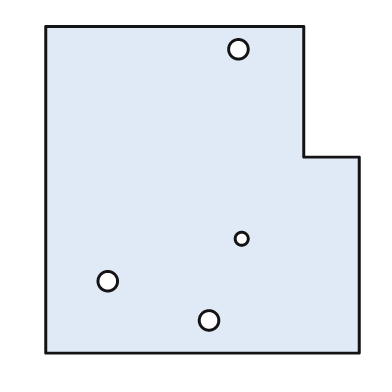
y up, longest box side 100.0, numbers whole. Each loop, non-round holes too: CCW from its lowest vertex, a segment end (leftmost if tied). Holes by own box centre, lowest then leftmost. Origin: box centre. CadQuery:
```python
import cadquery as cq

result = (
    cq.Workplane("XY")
    .moveTo(-48.0, -50.0)
    .lineTo(48.0, -50.0)
    .lineTo(48.0, 10.0)
    .lineTo(31.0, 10.0)
    .lineTo(31.0, 50.0)
    .lineTo(-48.0, 50.0)
    .close()
    .moveTo(2.0, -40.0)
    .circle(3.0)
    .moveTo(-29.0, -28.0)
    .circle(3.0)
    .moveTo(12.0, -15.0)
    .circle(2.0)
    .moveTo(11.0, 43.0)
    .circle(3.0)
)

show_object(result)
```